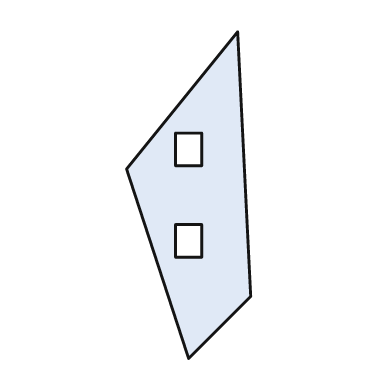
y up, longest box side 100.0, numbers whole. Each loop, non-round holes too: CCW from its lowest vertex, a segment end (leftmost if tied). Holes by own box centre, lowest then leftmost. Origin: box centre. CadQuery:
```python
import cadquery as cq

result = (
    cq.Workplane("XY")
    .moveTo(0.0, -50.0)
    .lineTo(19.0, -31.0)
    .lineTo(15.0, 50.0)
    .lineTo(-19.0, 8.0)
    .close()
    .moveTo(-4.0, -19.0)
    .lineTo(4.0, -19.0)
    .lineTo(4.0, -9.0)
    .lineTo(-4.0, -9.0)
    .close()
    .moveTo(-4.0, 9.0)
    .lineTo(4.0, 9.0)
    .lineTo(4.0, 19.0)
    .lineTo(-4.0, 19.0)
    .close()
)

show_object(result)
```